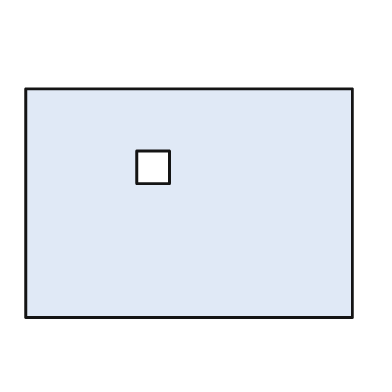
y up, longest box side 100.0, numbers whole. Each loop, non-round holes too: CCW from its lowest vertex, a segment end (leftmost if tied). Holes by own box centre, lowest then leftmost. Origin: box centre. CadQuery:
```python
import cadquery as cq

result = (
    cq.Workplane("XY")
    .moveTo(-50.0, -35.0)
    .lineTo(50.0, -35.0)
    .lineTo(50.0, 35.0)
    .lineTo(-50.0, 35.0)
    .close()
    .moveTo(-16.0, 6.0)
    .lineTo(-6.0, 6.0)
    .lineTo(-6.0, 16.0)
    .lineTo(-16.0, 16.0)
    .close()
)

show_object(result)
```